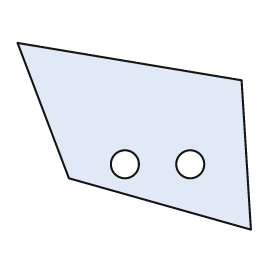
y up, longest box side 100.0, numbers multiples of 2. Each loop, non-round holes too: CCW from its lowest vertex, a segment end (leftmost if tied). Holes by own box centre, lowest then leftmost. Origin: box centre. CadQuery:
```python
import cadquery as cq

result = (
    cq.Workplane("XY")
    .moveTo(50.0, -40.0)
    .lineTo(46.0, 24.0)
    .lineTo(-50.0, 40.0)
    .lineTo(-28.0, -18.0)
    .close()
    .moveTo(-4.0, -12.0)
    .circle(6.0)
    .moveTo(24.0, -12.0)
    .circle(6.0)
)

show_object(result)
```